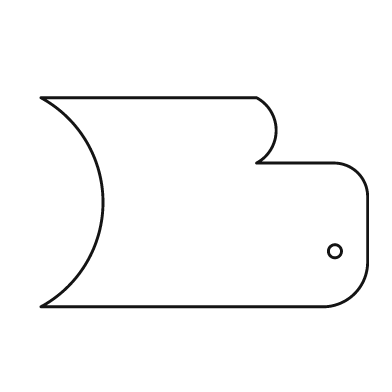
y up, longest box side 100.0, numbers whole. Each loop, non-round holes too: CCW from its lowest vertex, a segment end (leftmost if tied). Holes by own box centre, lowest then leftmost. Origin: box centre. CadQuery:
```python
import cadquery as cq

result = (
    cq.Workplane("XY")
    .moveTo(-50.0, -32.0)
    .lineTo(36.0, -32.0)
    .threePointArc((46.0, -28.0), (50.0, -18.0))
    .lineTo(50.0, 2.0)
    .threePointArc((47.0, 9.0), (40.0, 12.0))
    .lineTo(16.0, 12.0)
    .threePointArc((22.0, 22.0), (16.0, 32.0))
    .lineTo(-50.0, 32.0)
    .threePointArc((-31.0, 0.0), (-50.0, -32.0))
    .close()
    .moveTo(40.0, -15.0)
    .circle(2.0)
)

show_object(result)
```